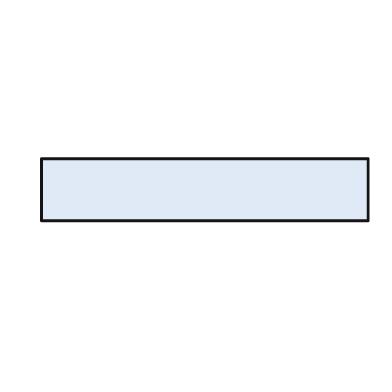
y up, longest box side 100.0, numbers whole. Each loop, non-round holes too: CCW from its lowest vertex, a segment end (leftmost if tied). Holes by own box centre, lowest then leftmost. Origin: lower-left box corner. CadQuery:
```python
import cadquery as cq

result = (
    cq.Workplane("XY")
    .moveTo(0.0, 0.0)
    .lineTo(100.0, 0.0)
    .lineTo(100.0, 19.0)
    .lineTo(0.0, 19.0)
    .close()
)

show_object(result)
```